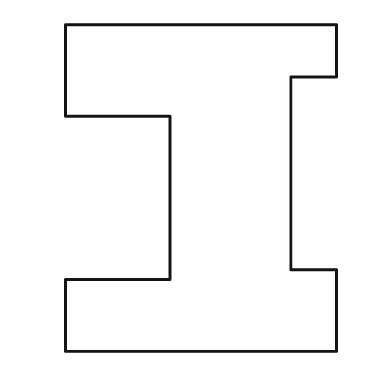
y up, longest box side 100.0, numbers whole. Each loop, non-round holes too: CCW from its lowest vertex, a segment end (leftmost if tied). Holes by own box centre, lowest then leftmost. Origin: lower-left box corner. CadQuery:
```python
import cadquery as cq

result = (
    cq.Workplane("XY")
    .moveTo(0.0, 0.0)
    .lineTo(83.0, 0.0)
    .lineTo(83.0, 25.0)
    .lineTo(69.0, 25.0)
    .lineTo(69.0, 84.0)
    .lineTo(83.0, 84.0)
    .lineTo(83.0, 100.0)
    .lineTo(0.0, 100.0)
    .lineTo(0.0, 72.0)
    .lineTo(32.0, 72.0)
    .lineTo(32.0, 22.0)
    .lineTo(0.0, 22.0)
    .close()
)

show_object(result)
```